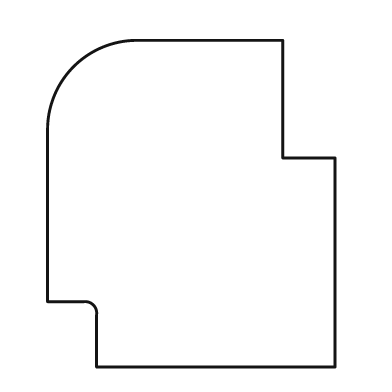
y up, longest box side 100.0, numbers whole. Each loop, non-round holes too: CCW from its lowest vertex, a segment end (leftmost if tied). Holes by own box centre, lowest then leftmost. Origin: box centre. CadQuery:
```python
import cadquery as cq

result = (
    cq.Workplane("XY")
    .moveTo(-29.0, -50.0)
    .lineTo(44.0, -50.0)
    .lineTo(44.0, 14.0)
    .lineTo(28.0, 14.0)
    .lineTo(28.0, 50.0)
    .lineTo(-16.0, 50.0)
    .threePointArc((-36.0, 42.0), (-44.0, 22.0))
    .lineTo(-44.0, -30.0)
    .lineTo(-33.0, -30.0)
    .threePointArc((-30.0, -31.0), (-29.0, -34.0))
    .close()
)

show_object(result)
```